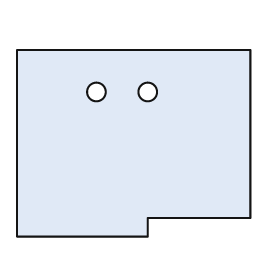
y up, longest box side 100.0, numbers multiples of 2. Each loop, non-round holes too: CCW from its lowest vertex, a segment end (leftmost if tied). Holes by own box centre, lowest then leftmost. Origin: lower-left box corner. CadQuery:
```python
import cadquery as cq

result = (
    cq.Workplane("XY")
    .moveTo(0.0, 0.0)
    .lineTo(56.0, 0.0)
    .lineTo(56.0, 8.0)
    .lineTo(100.0, 8.0)
    .lineTo(100.0, 80.0)
    .lineTo(0.0, 80.0)
    .close()
    .moveTo(34.0, 62.0)
    .circle(4.0)
    .moveTo(56.0, 62.0)
    .circle(4.0)
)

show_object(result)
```